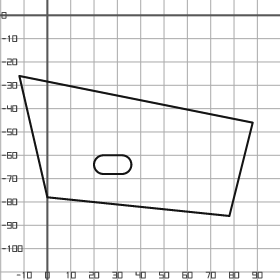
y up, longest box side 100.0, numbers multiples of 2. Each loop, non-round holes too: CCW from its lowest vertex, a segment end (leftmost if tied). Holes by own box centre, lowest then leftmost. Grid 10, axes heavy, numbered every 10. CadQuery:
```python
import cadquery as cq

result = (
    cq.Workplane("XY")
    .moveTo(78.0, -86.0)
    .lineTo(88.0, -46.0)
    .lineTo(-12.0, -26.0)
    .lineTo(0.0, -78.0)
    .close()
    .moveTo(24.0, -68.0)
    .lineTo(32.0, -68.0)
    .threePointArc((36.0, -64.0), (32.0, -60.0))
    .lineTo(24.0, -60.0)
    .threePointArc((20.0, -64.0), (24.0, -68.0))
    .close()
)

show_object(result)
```